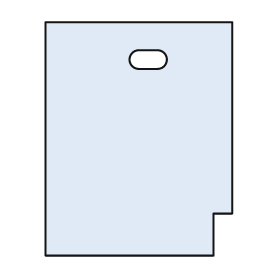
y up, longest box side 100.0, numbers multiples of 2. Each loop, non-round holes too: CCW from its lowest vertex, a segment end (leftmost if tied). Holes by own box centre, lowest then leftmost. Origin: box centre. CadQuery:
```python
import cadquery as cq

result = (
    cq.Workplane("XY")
    .moveTo(-40.0, -50.0)
    .lineTo(32.0, -50.0)
    .lineTo(32.0, -32.0)
    .lineTo(40.0, -32.0)
    .lineTo(40.0, 50.0)
    .lineTo(-40.0, 50.0)
    .close()
    .moveTo(0.0, 30.0)
    .lineTo(8.0, 30.0)
    .threePointArc((12.0, 34.0), (8.0, 38.0))
    .lineTo(0.0, 38.0)
    .threePointArc((-4.0, 34.0), (0.0, 30.0))
    .close()
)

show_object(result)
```